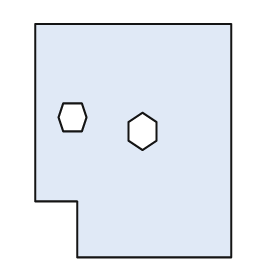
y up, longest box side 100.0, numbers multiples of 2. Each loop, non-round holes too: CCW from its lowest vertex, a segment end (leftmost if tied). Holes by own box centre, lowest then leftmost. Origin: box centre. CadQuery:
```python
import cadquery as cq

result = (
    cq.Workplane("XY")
    .moveTo(-24.0, -50.0)
    .lineTo(42.0, -50.0)
    .lineTo(42.0, 50.0)
    .lineTo(-42.0, 50.0)
    .lineTo(-42.0, -26.0)
    .lineTo(-24.0, -26.0)
    .close()
    .moveTo(4.0, -4.0)
    .lineTo(10.0, 0.0)
    .lineTo(10.0, 8.0)
    .lineTo(4.0, 12.0)
    .lineTo(-2.0, 8.0)
    .lineTo(-2.0, 0.0)
    .close()
    .moveTo(-30.0, 4.0)
    .lineTo(-22.0, 4.0)
    .lineTo(-20.0, 10.0)
    .lineTo(-22.0, 16.0)
    .lineTo(-30.0, 16.0)
    .lineTo(-32.0, 10.0)
    .close()
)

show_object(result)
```